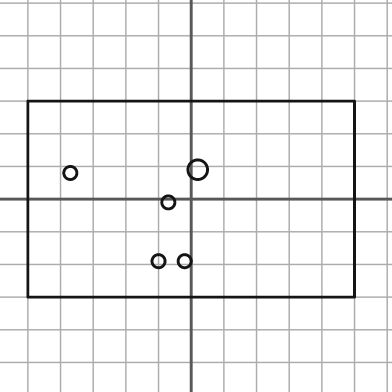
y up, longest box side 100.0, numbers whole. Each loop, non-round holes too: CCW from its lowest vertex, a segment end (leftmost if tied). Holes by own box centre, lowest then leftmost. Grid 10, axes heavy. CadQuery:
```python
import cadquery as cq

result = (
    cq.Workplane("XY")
    .moveTo(-50.0, -30.0)
    .lineTo(50.0, -30.0)
    .lineTo(50.0, 30.0)
    .lineTo(-50.0, 30.0)
    .close()
    .moveTo(-10.0, -19.0)
    .circle(2.0)
    .moveTo(-2.0, -19.0)
    .circle(2.0)
    .moveTo(-7.0, -1.0)
    .circle(2.0)
    .moveTo(-37.0, 8.0)
    .circle(2.0)
    .moveTo(2.0, 9.0)
    .circle(3.0)
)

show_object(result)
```